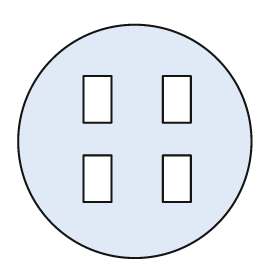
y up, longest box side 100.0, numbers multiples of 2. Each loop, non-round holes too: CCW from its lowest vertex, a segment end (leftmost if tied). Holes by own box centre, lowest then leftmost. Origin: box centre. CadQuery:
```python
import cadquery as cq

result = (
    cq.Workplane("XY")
    .moveTo(0.0, 0.0)
    .circle(50.0)
    .moveTo(-22.0, -26.0)
    .lineTo(-10.0, -26.0)
    .lineTo(-10.0, -6.0)
    .lineTo(-22.0, -6.0)
    .close()
    .moveTo(12.0, -26.0)
    .lineTo(24.0, -26.0)
    .lineTo(24.0, -6.0)
    .lineTo(12.0, -6.0)
    .close()
    .moveTo(-22.0, 8.0)
    .lineTo(-10.0, 8.0)
    .lineTo(-10.0, 28.0)
    .lineTo(-22.0, 28.0)
    .close()
    .moveTo(12.0, 8.0)
    .lineTo(24.0, 8.0)
    .lineTo(24.0, 28.0)
    .lineTo(12.0, 28.0)
    .close()
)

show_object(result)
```